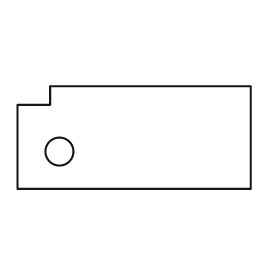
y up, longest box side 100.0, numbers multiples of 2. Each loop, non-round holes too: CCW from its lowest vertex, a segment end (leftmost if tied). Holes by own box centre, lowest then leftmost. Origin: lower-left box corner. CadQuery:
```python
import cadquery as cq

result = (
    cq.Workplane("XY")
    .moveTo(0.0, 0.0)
    .lineTo(100.0, 0.0)
    .lineTo(100.0, 44.0)
    .lineTo(14.0, 44.0)
    .lineTo(14.0, 36.0)
    .lineTo(0.0, 36.0)
    .close()
    .moveTo(18.0, 16.0)
    .circle(6.0)
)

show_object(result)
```